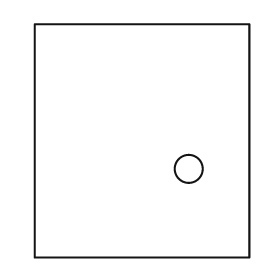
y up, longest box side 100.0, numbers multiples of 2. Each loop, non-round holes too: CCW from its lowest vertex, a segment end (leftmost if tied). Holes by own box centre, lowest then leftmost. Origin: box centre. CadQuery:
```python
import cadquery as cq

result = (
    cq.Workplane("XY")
    .moveTo(-46.0, -50.0)
    .lineTo(46.0, -50.0)
    .lineTo(46.0, 50.0)
    .lineTo(-46.0, 50.0)
    .close()
    .moveTo(20.0, -12.0)
    .circle(6.0)
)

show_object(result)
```